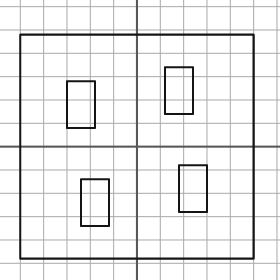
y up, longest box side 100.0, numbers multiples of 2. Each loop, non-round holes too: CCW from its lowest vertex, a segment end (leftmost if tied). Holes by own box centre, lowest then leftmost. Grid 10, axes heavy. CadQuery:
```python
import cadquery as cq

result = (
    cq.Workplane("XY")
    .moveTo(-50.0, -48.0)
    .lineTo(50.0, -48.0)
    .lineTo(50.0, 48.0)
    .lineTo(-50.0, 48.0)
    .close()
    .moveTo(-24.0, -34.0)
    .lineTo(-12.0, -34.0)
    .lineTo(-12.0, -14.0)
    .lineTo(-24.0, -14.0)
    .close()
    .moveTo(18.0, -28.0)
    .lineTo(30.0, -28.0)
    .lineTo(30.0, -8.0)
    .lineTo(18.0, -8.0)
    .close()
    .moveTo(-30.0, 8.0)
    .lineTo(-18.0, 8.0)
    .lineTo(-18.0, 28.0)
    .lineTo(-30.0, 28.0)
    .close()
    .moveTo(12.0, 14.0)
    .lineTo(24.0, 14.0)
    .lineTo(24.0, 34.0)
    .lineTo(12.0, 34.0)
    .close()
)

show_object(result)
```